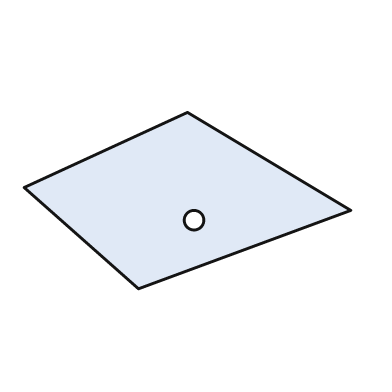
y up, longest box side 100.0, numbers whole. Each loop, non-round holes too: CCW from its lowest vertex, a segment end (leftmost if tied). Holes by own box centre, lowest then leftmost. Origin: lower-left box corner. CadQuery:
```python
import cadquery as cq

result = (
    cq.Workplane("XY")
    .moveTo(35.0, 0.0)
    .lineTo(100.0, 24.0)
    .lineTo(50.0, 54.0)
    .lineTo(0.0, 31.0)
    .close()
    .moveTo(52.0, 21.0)
    .circle(3.0)
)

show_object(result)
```